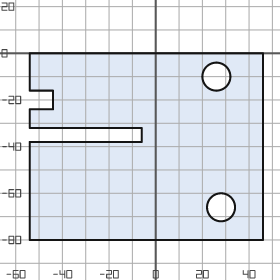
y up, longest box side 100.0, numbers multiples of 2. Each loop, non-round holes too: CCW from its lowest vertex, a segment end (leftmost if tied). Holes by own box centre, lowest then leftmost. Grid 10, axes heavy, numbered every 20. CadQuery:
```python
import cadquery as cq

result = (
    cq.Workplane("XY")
    .moveTo(-54.0, -80.0)
    .lineTo(46.0, -80.0)
    .lineTo(46.0, 0.0)
    .lineTo(-54.0, 0.0)
    .lineTo(-54.0, -16.0)
    .lineTo(-44.0, -16.0)
    .lineTo(-44.0, -24.0)
    .lineTo(-54.0, -24.0)
    .lineTo(-54.0, -32.0)
    .lineTo(-6.0, -32.0)
    .lineTo(-6.0, -38.0)
    .lineTo(-54.0, -38.0)
    .close()
    .moveTo(28.0, -66.0)
    .circle(6.0)
    .moveTo(26.0, -10.0)
    .circle(6.0)
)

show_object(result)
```